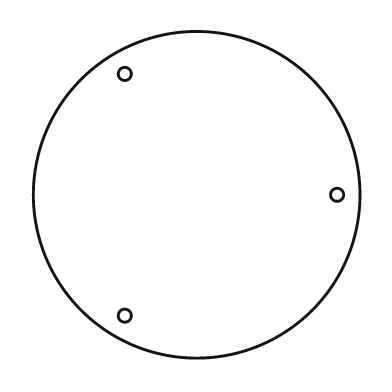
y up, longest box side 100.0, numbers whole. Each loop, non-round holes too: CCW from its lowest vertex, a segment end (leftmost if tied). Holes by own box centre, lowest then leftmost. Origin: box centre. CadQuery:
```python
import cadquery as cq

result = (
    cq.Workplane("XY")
    .moveTo(0.0, 0.0)
    .circle(50.0)
    .moveTo(-22.0, -37.0)
    .circle(2.0)
    .moveTo(43.0, 0.0)
    .circle(2.0)
    .moveTo(-22.0, 37.0)
    .circle(2.0)
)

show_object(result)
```